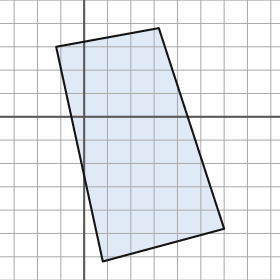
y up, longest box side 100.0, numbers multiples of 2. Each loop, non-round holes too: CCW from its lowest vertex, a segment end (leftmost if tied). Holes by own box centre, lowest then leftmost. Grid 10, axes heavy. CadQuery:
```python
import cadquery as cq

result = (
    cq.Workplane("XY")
    .moveTo(8.0, -62.0)
    .lineTo(60.0, -48.0)
    .lineTo(32.0, 38.0)
    .lineTo(-12.0, 30.0)
    .close()
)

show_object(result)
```